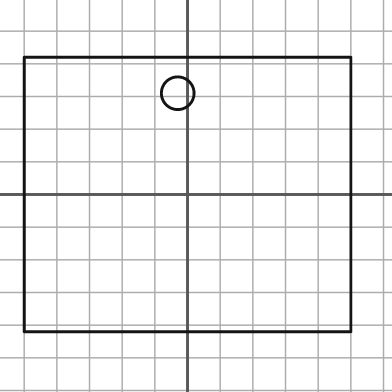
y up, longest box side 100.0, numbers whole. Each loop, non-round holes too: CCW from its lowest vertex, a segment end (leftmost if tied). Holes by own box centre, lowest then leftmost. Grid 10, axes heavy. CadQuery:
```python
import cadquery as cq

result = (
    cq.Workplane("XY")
    .moveTo(-50.0, -42.0)
    .lineTo(50.0, -42.0)
    .lineTo(50.0, 42.0)
    .lineTo(-50.0, 42.0)
    .close()
    .moveTo(-3.0, 31.0)
    .circle(5.0)
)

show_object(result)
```